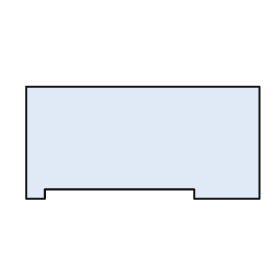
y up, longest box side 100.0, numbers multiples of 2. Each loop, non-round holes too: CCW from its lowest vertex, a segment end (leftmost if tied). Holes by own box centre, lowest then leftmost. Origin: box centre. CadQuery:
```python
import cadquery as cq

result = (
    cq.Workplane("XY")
    .moveTo(-50.0, -24.0)
    .lineTo(-42.0, -24.0)
    .lineTo(-42.0, -20.0)
    .lineTo(22.0, -20.0)
    .lineTo(22.0, -24.0)
    .lineTo(50.0, -24.0)
    .lineTo(50.0, 24.0)
    .lineTo(-50.0, 24.0)
    .close()
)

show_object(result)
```